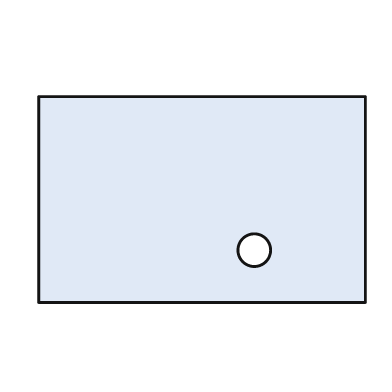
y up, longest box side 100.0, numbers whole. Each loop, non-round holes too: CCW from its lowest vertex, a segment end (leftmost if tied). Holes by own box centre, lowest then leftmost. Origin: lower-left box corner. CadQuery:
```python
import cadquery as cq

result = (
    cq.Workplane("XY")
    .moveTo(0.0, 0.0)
    .lineTo(100.0, 0.0)
    .lineTo(100.0, 63.0)
    .lineTo(0.0, 63.0)
    .close()
    .moveTo(66.0, 16.0)
    .circle(5.0)
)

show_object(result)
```